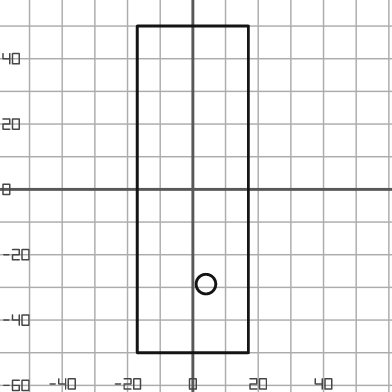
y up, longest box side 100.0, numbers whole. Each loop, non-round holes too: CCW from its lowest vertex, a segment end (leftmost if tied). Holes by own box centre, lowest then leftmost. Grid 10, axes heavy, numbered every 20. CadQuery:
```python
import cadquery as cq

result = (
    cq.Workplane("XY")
    .moveTo(-17.0, -50.0)
    .lineTo(17.0, -50.0)
    .lineTo(17.0, 50.0)
    .lineTo(-17.0, 50.0)
    .close()
    .moveTo(4.0, -29.0)
    .circle(3.0)
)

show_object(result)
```